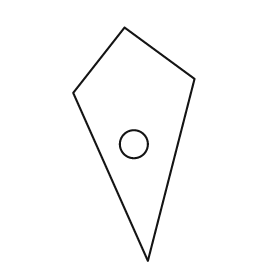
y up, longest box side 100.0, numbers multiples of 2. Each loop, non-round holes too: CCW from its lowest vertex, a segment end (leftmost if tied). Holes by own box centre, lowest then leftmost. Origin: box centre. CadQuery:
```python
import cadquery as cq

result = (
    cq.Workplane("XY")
    .moveTo(6.0, -50.0)
    .lineTo(26.0, 28.0)
    .lineTo(-4.0, 50.0)
    .lineTo(-26.0, 22.0)
    .close()
    .moveTo(0.0, 0.0)
    .circle(6.0)
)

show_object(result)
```